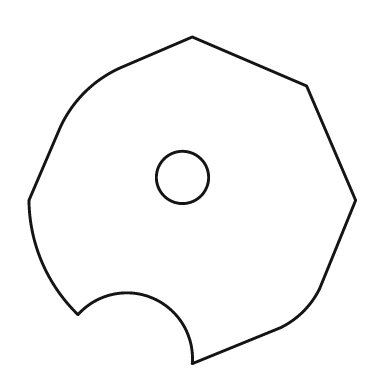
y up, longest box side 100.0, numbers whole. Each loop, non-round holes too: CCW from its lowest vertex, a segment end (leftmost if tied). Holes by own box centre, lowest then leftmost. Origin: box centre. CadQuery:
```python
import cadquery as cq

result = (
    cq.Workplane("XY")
    .moveTo(0.0, -50.0)
    .lineTo(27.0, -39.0)
    .threePointArc((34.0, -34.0), (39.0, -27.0))
    .lineTo(50.0, 0.0)
    .lineTo(35.0, 35.0)
    .lineTo(0.0, 50.0)
    .lineTo(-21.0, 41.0)
    .threePointArc((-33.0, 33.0), (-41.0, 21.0))
    .lineTo(-50.0, 0.0)
    .threePointArc((-46.0, -19.0), (-35.0, -35.0))
    .threePointArc((-12.0, -30.0), (0.0, -50.0))
    .close()
    .moveTo(-3.0, 7.0)
    .circle(8.0)
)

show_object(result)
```